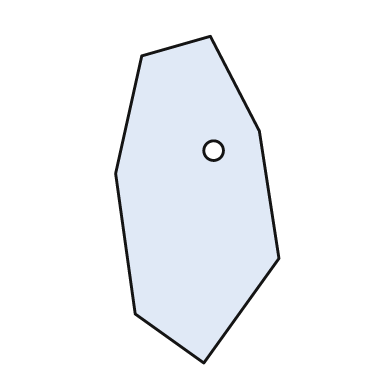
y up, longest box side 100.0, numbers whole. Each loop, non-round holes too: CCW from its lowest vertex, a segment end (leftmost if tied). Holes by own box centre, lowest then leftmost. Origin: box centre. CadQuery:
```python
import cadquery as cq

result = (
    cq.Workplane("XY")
    .moveTo(2.0, -50.0)
    .lineTo(25.0, -18.0)
    .lineTo(19.0, 21.0)
    .lineTo(4.0, 50.0)
    .lineTo(-17.0, 44.0)
    .lineTo(-25.0, 8.0)
    .lineTo(-19.0, -35.0)
    .close()
    .moveTo(5.0, 15.0)
    .circle(3.0)
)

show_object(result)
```